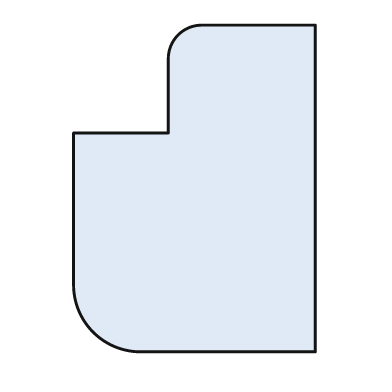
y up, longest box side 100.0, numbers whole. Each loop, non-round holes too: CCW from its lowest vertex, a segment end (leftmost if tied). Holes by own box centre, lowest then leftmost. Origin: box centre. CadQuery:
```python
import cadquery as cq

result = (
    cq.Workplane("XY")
    .moveTo(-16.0, -50.0)
    .lineTo(37.0, -50.0)
    .lineTo(37.0, 50.0)
    .lineTo(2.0, 50.0)
    .threePointArc((-5.0, 47.0), (-8.0, 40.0))
    .lineTo(-8.0, 17.0)
    .lineTo(-37.0, 17.0)
    .lineTo(-37.0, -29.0)
    .threePointArc((-31.0, -44.0), (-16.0, -50.0))
    .close()
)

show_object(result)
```